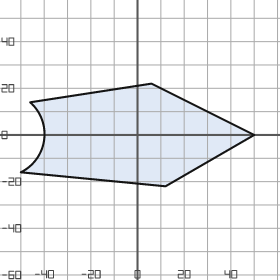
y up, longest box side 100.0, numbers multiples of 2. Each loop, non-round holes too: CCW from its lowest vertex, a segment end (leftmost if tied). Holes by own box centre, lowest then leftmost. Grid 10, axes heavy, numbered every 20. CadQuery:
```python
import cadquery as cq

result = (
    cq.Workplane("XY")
    .moveTo(12.0, -22.0)
    .lineTo(50.0, 0.0)
    .lineTo(6.0, 22.0)
    .lineTo(-46.0, 14.0)
    .threePointArc((-40.0, -2.0), (-50.0, -16.0))
    .close()
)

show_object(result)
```